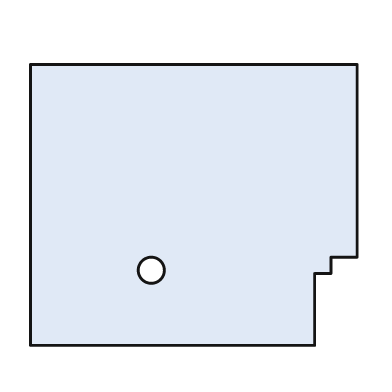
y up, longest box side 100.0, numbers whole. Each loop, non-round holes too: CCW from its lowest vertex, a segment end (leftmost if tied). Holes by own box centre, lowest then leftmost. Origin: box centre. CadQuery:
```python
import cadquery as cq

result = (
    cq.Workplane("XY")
    .moveTo(-50.0, -43.0)
    .lineTo(37.0, -43.0)
    .lineTo(37.0, -21.0)
    .lineTo(42.0, -21.0)
    .lineTo(42.0, -16.0)
    .lineTo(50.0, -16.0)
    .lineTo(50.0, 43.0)
    .lineTo(-50.0, 43.0)
    .close()
    .moveTo(-13.0, -20.0)
    .circle(4.0)
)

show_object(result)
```